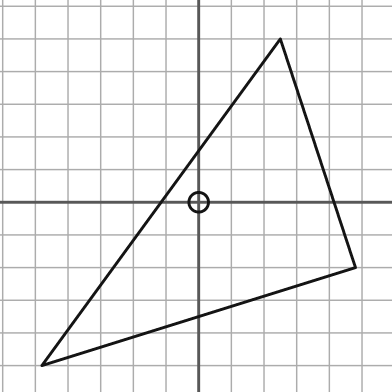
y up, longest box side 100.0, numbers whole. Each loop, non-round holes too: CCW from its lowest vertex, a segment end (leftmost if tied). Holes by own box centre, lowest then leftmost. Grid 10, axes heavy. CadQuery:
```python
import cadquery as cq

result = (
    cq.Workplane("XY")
    .moveTo(-48.0, -50.0)
    .lineTo(48.0, -20.0)
    .lineTo(25.0, 50.0)
    .close()
    .moveTo(0.0, 0.0)
    .circle(3.0)
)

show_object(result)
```